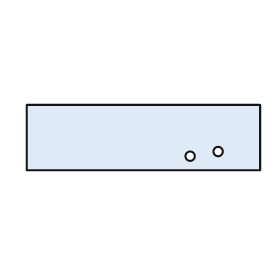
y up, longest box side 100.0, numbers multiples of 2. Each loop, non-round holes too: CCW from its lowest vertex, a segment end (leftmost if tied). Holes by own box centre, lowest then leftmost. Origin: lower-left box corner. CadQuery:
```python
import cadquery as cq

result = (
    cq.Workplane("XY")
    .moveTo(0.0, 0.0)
    .lineTo(100.0, 0.0)
    .lineTo(100.0, 28.0)
    .lineTo(0.0, 28.0)
    .close()
    .moveTo(70.0, 6.0)
    .circle(2.0)
    .moveTo(82.0, 8.0)
    .circle(2.0)
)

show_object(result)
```